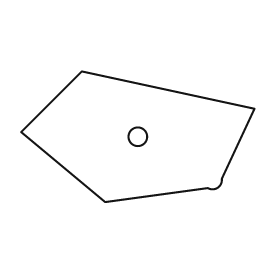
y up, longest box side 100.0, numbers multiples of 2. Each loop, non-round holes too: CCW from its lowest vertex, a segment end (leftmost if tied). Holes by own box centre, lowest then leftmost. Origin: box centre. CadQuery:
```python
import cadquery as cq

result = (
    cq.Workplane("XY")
    .moveTo(-14.0, -28.0)
    .lineTo(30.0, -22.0)
    .threePointArc((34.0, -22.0), (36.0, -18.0))
    .lineTo(50.0, 12.0)
    .lineTo(-24.0, 28.0)
    .lineTo(-50.0, 2.0)
    .close()
    .moveTo(0.0, 0.0)
    .circle(4.0)
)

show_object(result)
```